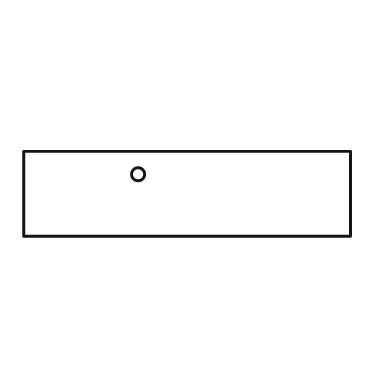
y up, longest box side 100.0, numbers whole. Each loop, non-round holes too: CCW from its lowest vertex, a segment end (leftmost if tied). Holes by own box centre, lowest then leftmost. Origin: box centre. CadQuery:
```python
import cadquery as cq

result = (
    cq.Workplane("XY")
    .moveTo(-50.0, -13.0)
    .lineTo(50.0, -13.0)
    .lineTo(50.0, 13.0)
    .lineTo(-50.0, 13.0)
    .close()
    .moveTo(-15.0, 6.0)
    .circle(2.0)
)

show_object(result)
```